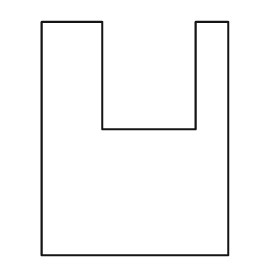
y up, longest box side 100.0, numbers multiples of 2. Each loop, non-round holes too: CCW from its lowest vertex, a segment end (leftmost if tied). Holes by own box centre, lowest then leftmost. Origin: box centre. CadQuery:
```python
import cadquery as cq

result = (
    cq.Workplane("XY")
    .moveTo(-40.0, -50.0)
    .lineTo(40.0, -50.0)
    .lineTo(40.0, 50.0)
    .lineTo(26.0, 50.0)
    .lineTo(26.0, 4.0)
    .lineTo(-14.0, 4.0)
    .lineTo(-14.0, 50.0)
    .lineTo(-40.0, 50.0)
    .close()
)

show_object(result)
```